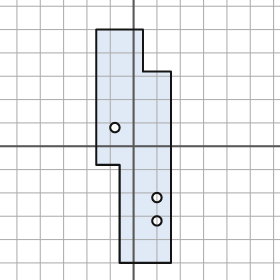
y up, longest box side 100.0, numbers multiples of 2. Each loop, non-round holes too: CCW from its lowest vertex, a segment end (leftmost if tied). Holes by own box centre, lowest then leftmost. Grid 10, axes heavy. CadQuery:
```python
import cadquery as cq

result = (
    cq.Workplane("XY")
    .moveTo(-6.0, -50.0)
    .lineTo(16.0, -50.0)
    .lineTo(16.0, 32.0)
    .lineTo(4.0, 32.0)
    .lineTo(4.0, 50.0)
    .lineTo(-16.0, 50.0)
    .lineTo(-16.0, -8.0)
    .lineTo(-6.0, -8.0)
    .close()
    .moveTo(10.0, -32.0)
    .circle(2.0)
    .moveTo(10.0, -22.0)
    .circle(2.0)
    .moveTo(-8.0, 8.0)
    .circle(2.0)
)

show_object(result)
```